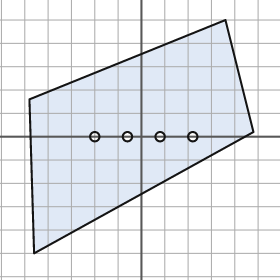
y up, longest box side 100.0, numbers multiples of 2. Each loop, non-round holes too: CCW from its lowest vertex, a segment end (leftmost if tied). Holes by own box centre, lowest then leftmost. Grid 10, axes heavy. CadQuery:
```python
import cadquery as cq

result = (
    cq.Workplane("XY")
    .moveTo(-46.0, -50.0)
    .lineTo(48.0, 2.0)
    .lineTo(36.0, 50.0)
    .lineTo(-48.0, 16.0)
    .close()
    .moveTo(-20.0, 0.0)
    .circle(2.0)
    .moveTo(-6.0, 0.0)
    .circle(2.0)
    .moveTo(8.0, 0.0)
    .circle(2.0)
    .moveTo(22.0, 0.0)
    .circle(2.0)
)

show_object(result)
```